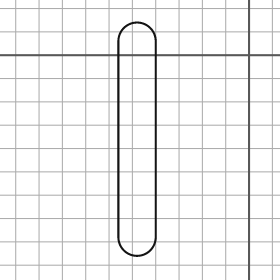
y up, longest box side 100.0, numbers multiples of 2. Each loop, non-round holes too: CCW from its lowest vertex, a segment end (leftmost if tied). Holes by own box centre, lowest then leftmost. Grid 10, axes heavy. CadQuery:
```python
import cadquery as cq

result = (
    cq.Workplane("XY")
    .moveTo(-56.0, -78.0)
    .threePointArc((-48.0, -86.0), (-40.0, -78.0))
    .lineTo(-40.0, 6.0)
    .threePointArc((-48.0, 14.0), (-56.0, 6.0))
    .close()
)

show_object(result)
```